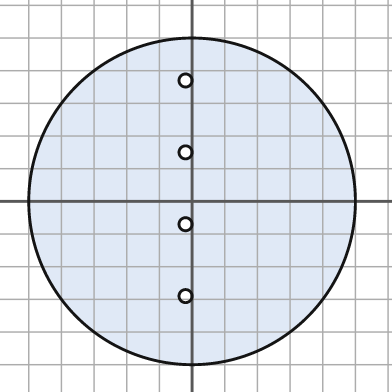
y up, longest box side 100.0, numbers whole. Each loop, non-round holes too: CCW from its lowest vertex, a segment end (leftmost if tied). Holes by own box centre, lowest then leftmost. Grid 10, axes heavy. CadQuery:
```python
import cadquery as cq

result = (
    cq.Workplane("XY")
    .moveTo(0.0, 0.0)
    .circle(50.0)
    .moveTo(-2.0, -29.0)
    .circle(2.0)
    .moveTo(-2.0, -7.0)
    .circle(2.0)
    .moveTo(-2.0, 15.0)
    .circle(2.0)
    .moveTo(-2.0, 37.0)
    .circle(2.0)
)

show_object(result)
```